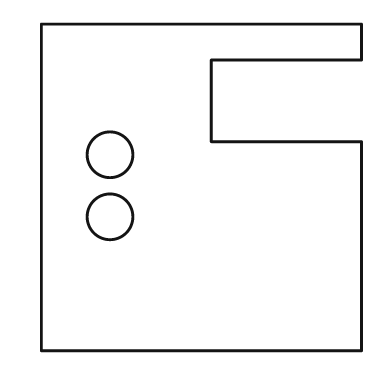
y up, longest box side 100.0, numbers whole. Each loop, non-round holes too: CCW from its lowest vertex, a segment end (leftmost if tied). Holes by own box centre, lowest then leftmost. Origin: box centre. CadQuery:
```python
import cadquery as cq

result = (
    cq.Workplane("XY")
    .moveTo(-49.0, -50.0)
    .lineTo(49.0, -50.0)
    .lineTo(49.0, 14.0)
    .lineTo(3.0, 14.0)
    .lineTo(3.0, 39.0)
    .lineTo(49.0, 39.0)
    .lineTo(49.0, 50.0)
    .lineTo(-49.0, 50.0)
    .close()
    .moveTo(-28.0, -9.0)
    .circle(7.0)
    .moveTo(-28.0, 10.0)
    .circle(7.0)
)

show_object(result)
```